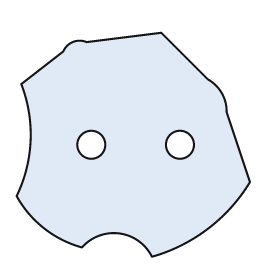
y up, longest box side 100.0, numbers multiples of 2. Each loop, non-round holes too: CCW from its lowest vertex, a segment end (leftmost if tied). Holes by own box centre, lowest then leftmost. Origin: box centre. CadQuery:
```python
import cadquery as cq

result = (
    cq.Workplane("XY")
    .moveTo(8.0, -48.0)
    .threePointArc((32.0, -36.0), (50.0, -16.0))
    .lineTo(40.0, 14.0)
    .threePointArc((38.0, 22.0), (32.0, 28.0))
    .lineTo(12.0, 48.0)
    .lineTo(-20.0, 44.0)
    .threePointArc((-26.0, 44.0), (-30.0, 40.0))
    .lineTo(-48.0, 26.0)
    .threePointArc((-44.0, 2.0), (-50.0, -22.0))
    .threePointArc((-38.0, -36.0), (-22.0, -44.0))
    .threePointArc((-6.0, -38.0), (8.0, -48.0))
    .close()
    .moveTo(-18.0, 0.0)
    .circle(6.0)
    .moveTo(20.0, 0.0)
    .circle(6.0)
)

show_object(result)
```